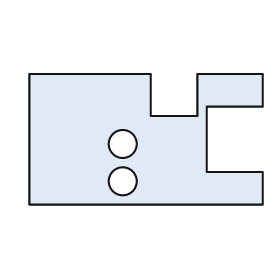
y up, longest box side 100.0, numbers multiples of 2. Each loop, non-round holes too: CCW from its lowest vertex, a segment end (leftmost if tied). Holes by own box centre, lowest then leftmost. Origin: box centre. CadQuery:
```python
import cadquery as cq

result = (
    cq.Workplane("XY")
    .moveTo(-50.0, -28.0)
    .lineTo(50.0, -28.0)
    .lineTo(50.0, -14.0)
    .lineTo(26.0, -14.0)
    .lineTo(26.0, 14.0)
    .lineTo(50.0, 14.0)
    .lineTo(50.0, 28.0)
    .lineTo(22.0, 28.0)
    .lineTo(22.0, 10.0)
    .lineTo(2.0, 10.0)
    .lineTo(2.0, 28.0)
    .lineTo(-50.0, 28.0)
    .close()
    .moveTo(-10.0, -18.0)
    .circle(6.0)
    .moveTo(-10.0, -2.0)
    .circle(6.0)
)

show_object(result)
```